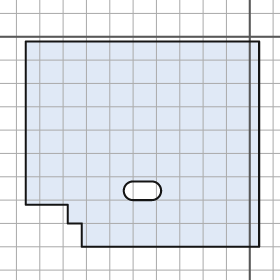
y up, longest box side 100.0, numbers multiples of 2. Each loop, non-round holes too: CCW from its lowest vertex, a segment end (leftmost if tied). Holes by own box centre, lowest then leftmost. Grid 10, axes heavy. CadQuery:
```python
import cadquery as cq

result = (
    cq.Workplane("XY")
    .moveTo(-72.0, -90.0)
    .lineTo(4.0, -90.0)
    .lineTo(4.0, -2.0)
    .lineTo(-96.0, -2.0)
    .lineTo(-96.0, -72.0)
    .lineTo(-78.0, -72.0)
    .lineTo(-78.0, -80.0)
    .lineTo(-72.0, -80.0)
    .close()
    .moveTo(-50.0, -70.0)
    .lineTo(-42.0, -70.0)
    .threePointArc((-38.0, -66.0), (-42.0, -62.0))
    .lineTo(-50.0, -62.0)
    .threePointArc((-54.0, -66.0), (-50.0, -70.0))
    .close()
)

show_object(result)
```